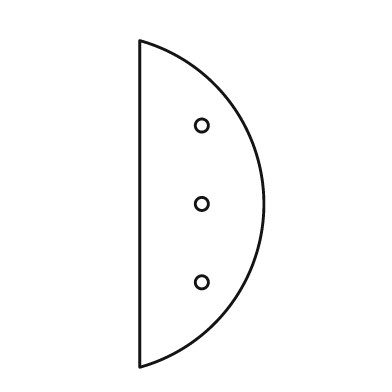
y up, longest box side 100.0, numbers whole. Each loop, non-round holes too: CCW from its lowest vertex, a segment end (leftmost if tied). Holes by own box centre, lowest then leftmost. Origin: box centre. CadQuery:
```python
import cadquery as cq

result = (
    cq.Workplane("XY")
    .moveTo(-19.0, -50.0)
    .threePointArc((19.0, 0.0), (-19.0, 50.0))
    .close()
    .moveTo(0.0, -24.0)
    .circle(2.0)
    .moveTo(0.0, 0.0)
    .circle(2.0)
    .moveTo(0.0, 24.0)
    .circle(2.0)
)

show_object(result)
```